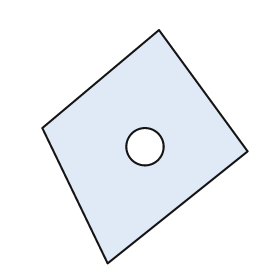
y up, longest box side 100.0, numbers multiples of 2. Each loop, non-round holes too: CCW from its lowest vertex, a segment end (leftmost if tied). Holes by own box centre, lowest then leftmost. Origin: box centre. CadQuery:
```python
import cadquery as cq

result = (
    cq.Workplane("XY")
    .moveTo(-16.0, -50.0)
    .lineTo(44.0, -2.0)
    .lineTo(6.0, 50.0)
    .lineTo(-44.0, 8.0)
    .close()
    .moveTo(0.0, 0.0)
    .circle(8.0)
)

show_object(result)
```